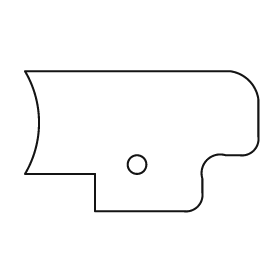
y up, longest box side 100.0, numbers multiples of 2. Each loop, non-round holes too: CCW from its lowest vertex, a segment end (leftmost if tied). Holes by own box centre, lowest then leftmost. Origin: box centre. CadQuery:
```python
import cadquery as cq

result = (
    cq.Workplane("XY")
    .moveTo(-20.0, -30.0)
    .lineTo(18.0, -30.0)
    .threePointArc((24.0, -28.0), (26.0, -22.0))
    .lineTo(26.0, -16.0)
    .threePointArc((28.0, -8.0), (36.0, -6.0))
    .lineTo(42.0, -6.0)
    .threePointArc((48.0, -4.0), (50.0, 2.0))
    .lineTo(50.0, 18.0)
    .threePointArc((46.0, 26.0), (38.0, 30.0))
    .lineTo(-50.0, 30.0)
    .threePointArc((-44.0, 8.0), (-50.0, -14.0))
    .lineTo(-20.0, -14.0)
    .close()
    .moveTo(-2.0, -10.0)
    .circle(4.0)
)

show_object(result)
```